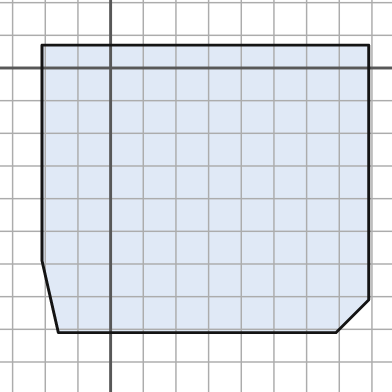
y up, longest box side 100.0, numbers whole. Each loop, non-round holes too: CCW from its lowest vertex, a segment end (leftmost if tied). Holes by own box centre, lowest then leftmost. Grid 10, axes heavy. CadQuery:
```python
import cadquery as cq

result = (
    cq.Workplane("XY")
    .moveTo(-16.0, -81.0)
    .lineTo(69.0, -81.0)
    .lineTo(79.0, -71.0)
    .lineTo(79.0, 7.0)
    .lineTo(-21.0, 7.0)
    .lineTo(-21.0, -59.0)
    .close()
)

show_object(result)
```